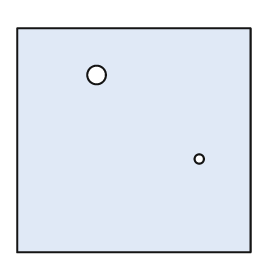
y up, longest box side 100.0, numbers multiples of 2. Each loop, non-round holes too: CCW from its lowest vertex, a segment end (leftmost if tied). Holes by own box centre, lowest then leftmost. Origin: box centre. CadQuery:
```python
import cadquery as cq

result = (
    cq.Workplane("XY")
    .moveTo(-50.0, -48.0)
    .lineTo(50.0, -48.0)
    .lineTo(50.0, 48.0)
    .lineTo(-50.0, 48.0)
    .close()
    .moveTo(28.0, -8.0)
    .circle(2.0)
    .moveTo(-16.0, 28.0)
    .circle(4.0)
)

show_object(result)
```